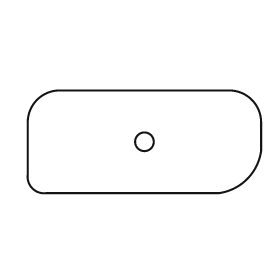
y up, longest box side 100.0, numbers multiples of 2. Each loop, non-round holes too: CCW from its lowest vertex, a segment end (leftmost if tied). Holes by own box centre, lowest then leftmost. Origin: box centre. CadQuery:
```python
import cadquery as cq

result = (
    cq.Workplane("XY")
    .moveTo(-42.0, -22.0)
    .lineTo(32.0, -22.0)
    .threePointArc((44.0, -16.0), (50.0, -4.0))
    .lineTo(50.0, 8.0)
    .threePointArc((46.0, 18.0), (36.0, 22.0))
    .lineTo(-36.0, 22.0)
    .threePointArc((-46.0, 18.0), (-50.0, 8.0))
    .lineTo(-50.0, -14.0)
    .threePointArc((-48.0, -20.0), (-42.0, -22.0))
    .close()
    .moveTo(0.0, 0.0)
    .circle(4.0)
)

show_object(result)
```